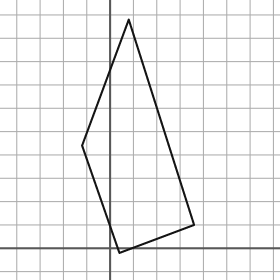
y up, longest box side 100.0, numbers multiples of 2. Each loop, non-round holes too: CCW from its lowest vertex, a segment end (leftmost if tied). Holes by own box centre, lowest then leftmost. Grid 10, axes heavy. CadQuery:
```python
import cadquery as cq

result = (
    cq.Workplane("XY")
    .moveTo(4.0, -2.0)
    .lineTo(36.0, 10.0)
    .lineTo(8.0, 98.0)
    .lineTo(-12.0, 44.0)
    .close()
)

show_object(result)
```